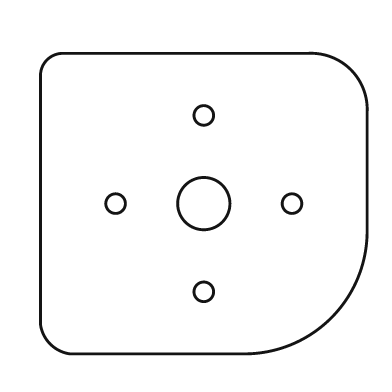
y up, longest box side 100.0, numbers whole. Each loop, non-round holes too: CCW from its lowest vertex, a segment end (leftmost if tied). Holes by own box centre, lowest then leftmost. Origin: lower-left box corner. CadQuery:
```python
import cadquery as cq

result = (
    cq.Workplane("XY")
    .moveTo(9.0, 0.0)
    .lineTo(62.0, 0.0)
    .threePointArc((89.0, 11.0), (100.0, 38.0))
    .lineTo(100.0, 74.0)
    .threePointArc((95.0, 87.0), (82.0, 92.0))
    .lineTo(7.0, 92.0)
    .threePointArc((2.0, 90.0), (0.0, 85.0))
    .lineTo(0.0, 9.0)
    .threePointArc((3.0, 3.0), (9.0, 0.0))
    .close()
    .moveTo(50.0, 19.0)
    .circle(3.0)
    .moveTo(23.0, 46.0)
    .circle(3.0)
    .moveTo(50.0, 46.0)
    .circle(8.0)
    .moveTo(77.0, 46.0)
    .circle(3.0)
    .moveTo(50.0, 73.0)
    .circle(3.0)
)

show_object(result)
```